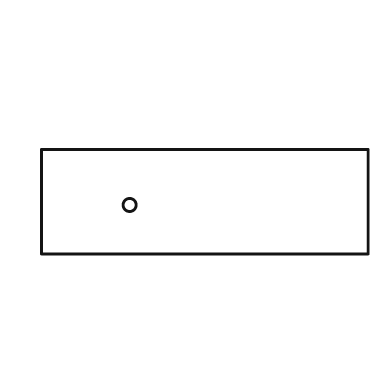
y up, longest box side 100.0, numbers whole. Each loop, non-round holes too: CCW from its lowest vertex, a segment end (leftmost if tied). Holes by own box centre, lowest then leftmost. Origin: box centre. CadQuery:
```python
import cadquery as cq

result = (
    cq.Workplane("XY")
    .moveTo(-50.0, -16.0)
    .lineTo(50.0, -16.0)
    .lineTo(50.0, 16.0)
    .lineTo(-50.0, 16.0)
    .close()
    .moveTo(-23.0, -1.0)
    .circle(2.0)
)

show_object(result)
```